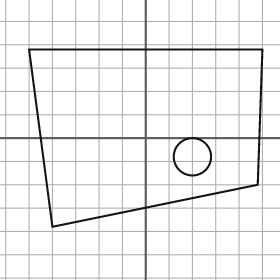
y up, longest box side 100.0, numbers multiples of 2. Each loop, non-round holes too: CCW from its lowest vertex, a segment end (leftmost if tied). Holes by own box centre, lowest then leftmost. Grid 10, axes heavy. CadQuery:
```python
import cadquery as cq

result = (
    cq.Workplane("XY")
    .moveTo(-40.0, -38.0)
    .lineTo(48.0, -20.0)
    .lineTo(50.0, 38.0)
    .lineTo(-50.0, 38.0)
    .close()
    .moveTo(20.0, -8.0)
    .circle(8.0)
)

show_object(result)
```